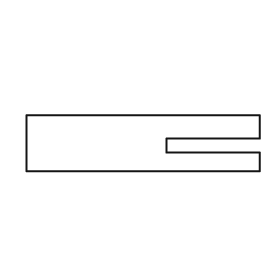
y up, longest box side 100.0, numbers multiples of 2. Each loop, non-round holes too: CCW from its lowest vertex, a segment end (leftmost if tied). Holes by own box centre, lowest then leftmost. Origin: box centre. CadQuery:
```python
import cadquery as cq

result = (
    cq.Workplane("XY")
    .moveTo(-50.0, -12.0)
    .lineTo(50.0, -12.0)
    .lineTo(50.0, -4.0)
    .lineTo(10.0, -4.0)
    .lineTo(10.0, 2.0)
    .lineTo(50.0, 2.0)
    .lineTo(50.0, 12.0)
    .lineTo(-50.0, 12.0)
    .close()
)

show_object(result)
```